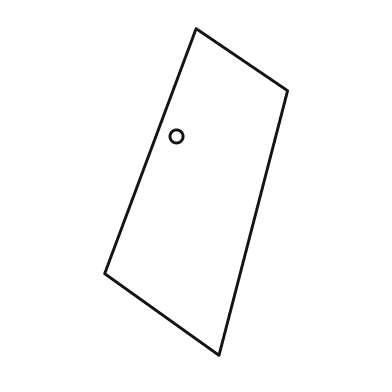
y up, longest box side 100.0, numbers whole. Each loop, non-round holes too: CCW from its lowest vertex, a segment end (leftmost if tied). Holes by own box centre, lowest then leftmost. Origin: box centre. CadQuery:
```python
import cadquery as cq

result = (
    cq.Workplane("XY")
    .moveTo(7.0, -50.0)
    .lineTo(28.0, 31.0)
    .lineTo(0.0, 50.0)
    .lineTo(-28.0, -25.0)
    .close()
    .moveTo(-6.0, 17.0)
    .circle(2.0)
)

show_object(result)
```